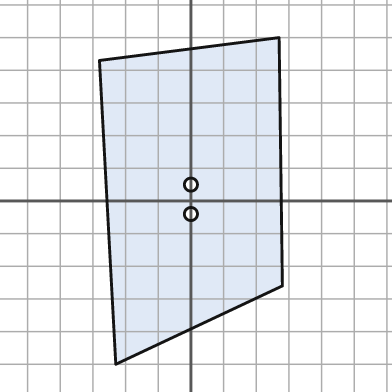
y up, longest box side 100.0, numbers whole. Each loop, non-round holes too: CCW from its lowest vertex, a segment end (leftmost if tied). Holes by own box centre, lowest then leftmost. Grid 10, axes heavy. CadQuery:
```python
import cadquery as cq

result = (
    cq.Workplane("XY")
    .moveTo(-23.0, -50.0)
    .lineTo(28.0, -26.0)
    .lineTo(27.0, 50.0)
    .lineTo(-28.0, 43.0)
    .close()
    .moveTo(0.0, -4.0)
    .circle(2.0)
    .moveTo(0.0, 5.0)
    .circle(2.0)
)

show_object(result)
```